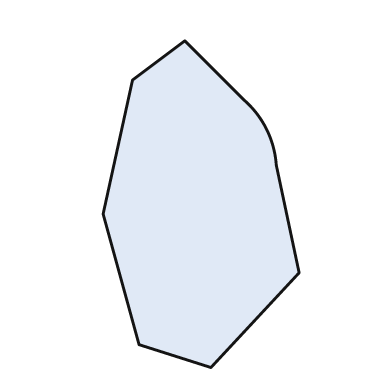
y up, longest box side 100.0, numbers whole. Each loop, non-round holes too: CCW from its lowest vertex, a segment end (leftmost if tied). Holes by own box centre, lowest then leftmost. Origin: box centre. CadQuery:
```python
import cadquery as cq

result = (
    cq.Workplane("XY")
    .moveTo(3.0, -50.0)
    .lineTo(30.0, -21.0)
    .lineTo(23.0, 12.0)
    .threePointArc((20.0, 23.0), (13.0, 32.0))
    .lineTo(-5.0, 50.0)
    .lineTo(-21.0, 38.0)
    .lineTo(-30.0, -3.0)
    .lineTo(-19.0, -43.0)
    .close()
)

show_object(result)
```